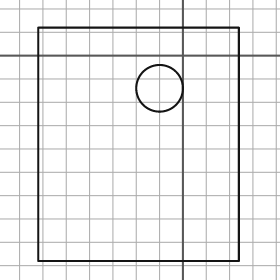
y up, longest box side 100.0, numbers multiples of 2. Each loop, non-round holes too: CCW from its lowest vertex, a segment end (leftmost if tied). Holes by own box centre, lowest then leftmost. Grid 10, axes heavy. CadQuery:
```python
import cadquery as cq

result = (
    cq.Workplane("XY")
    .moveTo(-62.0, -88.0)
    .lineTo(24.0, -88.0)
    .lineTo(24.0, 12.0)
    .lineTo(-62.0, 12.0)
    .close()
    .moveTo(-10.0, -14.0)
    .circle(10.0)
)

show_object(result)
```